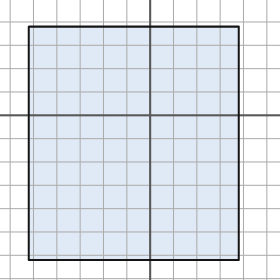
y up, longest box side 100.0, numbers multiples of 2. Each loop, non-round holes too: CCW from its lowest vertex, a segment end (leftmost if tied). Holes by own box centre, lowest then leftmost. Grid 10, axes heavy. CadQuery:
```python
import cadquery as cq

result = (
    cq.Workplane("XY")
    .moveTo(-52.0, -62.0)
    .lineTo(38.0, -62.0)
    .lineTo(38.0, 38.0)
    .lineTo(-52.0, 38.0)
    .close()
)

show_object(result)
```